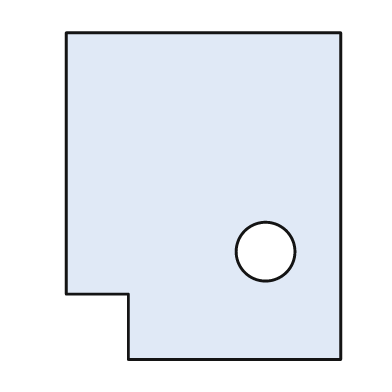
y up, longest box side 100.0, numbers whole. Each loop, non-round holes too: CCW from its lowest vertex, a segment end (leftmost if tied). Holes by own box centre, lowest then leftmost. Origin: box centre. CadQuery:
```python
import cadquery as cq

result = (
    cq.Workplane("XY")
    .moveTo(-23.0, -50.0)
    .lineTo(42.0, -50.0)
    .lineTo(42.0, 50.0)
    .lineTo(-42.0, 50.0)
    .lineTo(-42.0, -30.0)
    .lineTo(-23.0, -30.0)
    .close()
    .moveTo(19.0, -17.0)
    .circle(9.0)
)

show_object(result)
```